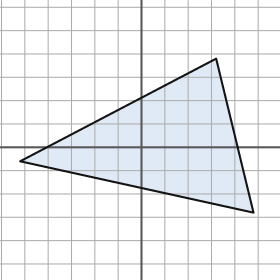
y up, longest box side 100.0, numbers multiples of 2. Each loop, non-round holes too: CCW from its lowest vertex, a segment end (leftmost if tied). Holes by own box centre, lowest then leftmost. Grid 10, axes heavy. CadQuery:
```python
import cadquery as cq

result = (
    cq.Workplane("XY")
    .moveTo(48.0, -28.0)
    .lineTo(32.0, 38.0)
    .lineTo(-52.0, -6.0)
    .close()
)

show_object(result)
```